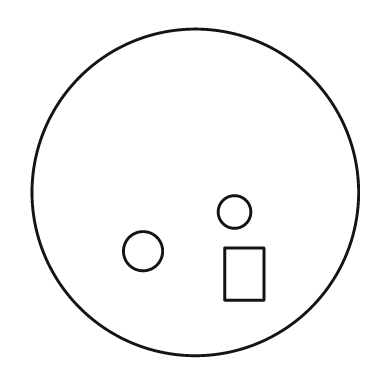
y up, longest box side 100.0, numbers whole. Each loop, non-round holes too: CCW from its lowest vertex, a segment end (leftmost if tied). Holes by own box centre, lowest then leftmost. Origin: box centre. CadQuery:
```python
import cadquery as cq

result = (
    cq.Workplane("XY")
    .moveTo(0.0, 0.0)
    .circle(50.0)
    .moveTo(9.0, -33.0)
    .lineTo(21.0, -33.0)
    .lineTo(21.0, -17.0)
    .lineTo(9.0, -17.0)
    .close()
    .moveTo(-16.0, -18.0)
    .circle(6.0)
    .moveTo(12.0, -6.0)
    .circle(5.0)
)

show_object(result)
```